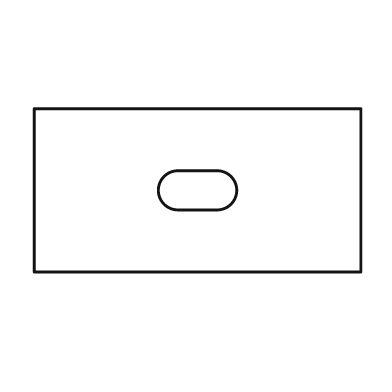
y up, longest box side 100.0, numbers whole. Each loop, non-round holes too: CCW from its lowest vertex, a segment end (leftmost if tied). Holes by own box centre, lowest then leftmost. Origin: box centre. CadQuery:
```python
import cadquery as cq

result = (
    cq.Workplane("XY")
    .moveTo(-50.0, -25.0)
    .lineTo(50.0, -25.0)
    .lineTo(50.0, 25.0)
    .lineTo(-50.0, 25.0)
    .close()
    .moveTo(-6.0, -6.0)
    .lineTo(6.0, -6.0)
    .threePointArc((12.0, 0.0), (6.0, 6.0))
    .lineTo(-6.0, 6.0)
    .threePointArc((-12.0, 0.0), (-6.0, -6.0))
    .close()
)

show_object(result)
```